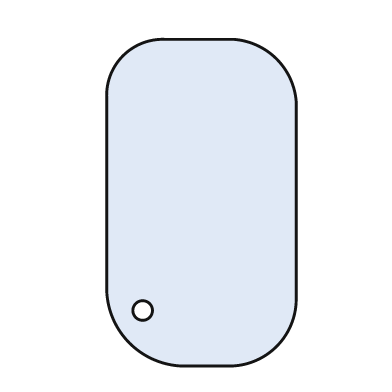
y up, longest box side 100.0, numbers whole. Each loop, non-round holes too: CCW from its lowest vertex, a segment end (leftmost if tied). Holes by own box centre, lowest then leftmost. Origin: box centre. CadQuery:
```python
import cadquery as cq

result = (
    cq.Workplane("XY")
    .moveTo(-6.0, -50.0)
    .lineTo(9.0, -50.0)
    .threePointArc((23.0, -44.0), (29.0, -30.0))
    .lineTo(29.0, 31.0)
    .threePointArc((23.0, 44.0), (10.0, 50.0))
    .lineTo(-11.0, 50.0)
    .threePointArc((-24.0, 45.0), (-29.0, 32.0))
    .lineTo(-29.0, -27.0)
    .threePointArc((-22.0, -43.0), (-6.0, -50.0))
    .close()
    .moveTo(-18.0, -33.0)
    .circle(3.0)
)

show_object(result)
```